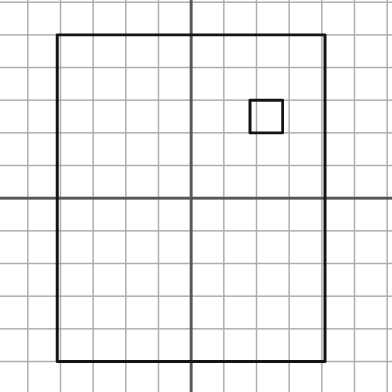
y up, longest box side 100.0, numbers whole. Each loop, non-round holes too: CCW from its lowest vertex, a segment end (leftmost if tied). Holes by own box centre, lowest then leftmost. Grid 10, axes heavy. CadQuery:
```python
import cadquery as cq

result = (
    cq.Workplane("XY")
    .moveTo(-41.0, -50.0)
    .lineTo(41.0, -50.0)
    .lineTo(41.0, 50.0)
    .lineTo(-41.0, 50.0)
    .close()
    .moveTo(18.0, 20.0)
    .lineTo(28.0, 20.0)
    .lineTo(28.0, 30.0)
    .lineTo(18.0, 30.0)
    .close()
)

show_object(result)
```